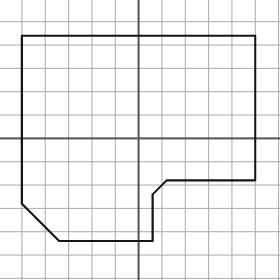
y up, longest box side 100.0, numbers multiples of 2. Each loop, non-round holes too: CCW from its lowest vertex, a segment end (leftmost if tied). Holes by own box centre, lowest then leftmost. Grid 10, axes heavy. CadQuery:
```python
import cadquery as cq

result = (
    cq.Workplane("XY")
    .moveTo(-34.0, -44.0)
    .lineTo(6.0, -44.0)
    .lineTo(6.0, -24.0)
    .lineTo(12.0, -18.0)
    .lineTo(50.0, -18.0)
    .lineTo(50.0, 44.0)
    .lineTo(-50.0, 44.0)
    .lineTo(-50.0, -28.0)
    .close()
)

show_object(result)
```